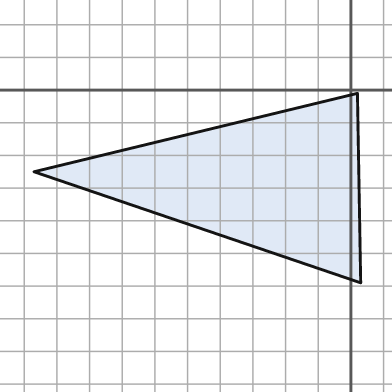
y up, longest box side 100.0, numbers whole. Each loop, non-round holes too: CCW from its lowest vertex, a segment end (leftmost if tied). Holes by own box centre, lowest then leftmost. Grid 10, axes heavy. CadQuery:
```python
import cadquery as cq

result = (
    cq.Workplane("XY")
    .moveTo(3.0, -59.0)
    .lineTo(2.0, -1.0)
    .lineTo(-97.0, -25.0)
    .close()
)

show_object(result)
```